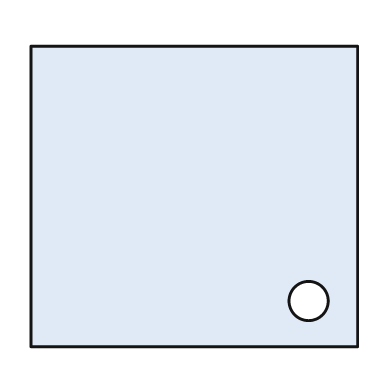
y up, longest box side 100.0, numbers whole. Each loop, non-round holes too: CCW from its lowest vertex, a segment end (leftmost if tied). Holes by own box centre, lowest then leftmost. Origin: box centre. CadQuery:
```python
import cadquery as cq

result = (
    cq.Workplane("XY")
    .moveTo(-50.0, -46.0)
    .lineTo(50.0, -46.0)
    .lineTo(50.0, 46.0)
    .lineTo(-50.0, 46.0)
    .close()
    .moveTo(35.0, -32.0)
    .circle(6.0)
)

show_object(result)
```